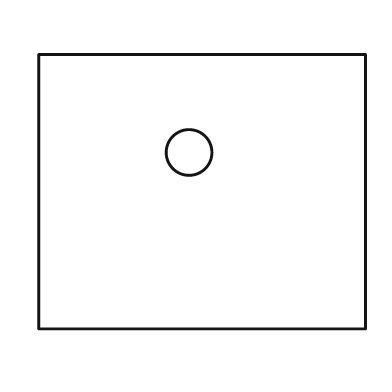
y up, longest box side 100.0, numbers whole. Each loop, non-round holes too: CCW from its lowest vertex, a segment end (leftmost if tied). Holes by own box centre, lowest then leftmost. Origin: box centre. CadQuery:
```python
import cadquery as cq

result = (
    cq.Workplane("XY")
    .moveTo(-50.0, -42.0)
    .lineTo(50.0, -42.0)
    .lineTo(50.0, 42.0)
    .lineTo(-50.0, 42.0)
    .close()
    .moveTo(-4.0, 12.0)
    .circle(7.0)
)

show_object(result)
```